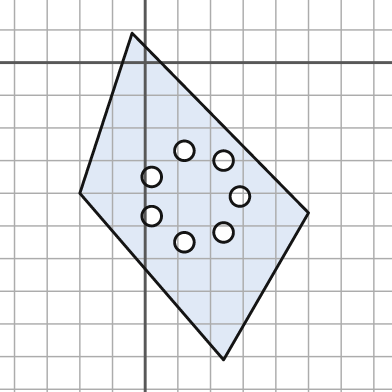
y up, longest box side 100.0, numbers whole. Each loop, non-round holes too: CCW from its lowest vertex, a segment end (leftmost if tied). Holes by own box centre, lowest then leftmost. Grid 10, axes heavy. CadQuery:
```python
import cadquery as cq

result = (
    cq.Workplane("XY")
    .moveTo(24.0, -91.0)
    .lineTo(50.0, -46.0)
    .lineTo(-4.0, 9.0)
    .lineTo(-20.0, -40.0)
    .close()
    .moveTo(12.0, -55.0)
    .circle(3.0)
    .moveTo(24.0, -52.0)
    .circle(3.0)
    .moveTo(2.0, -47.0)
    .circle(3.0)
    .moveTo(29.0, -41.0)
    .circle(3.0)
    .moveTo(2.0, -35.0)
    .circle(3.0)
    .moveTo(24.0, -30.0)
    .circle(3.0)
    .moveTo(12.0, -27.0)
    .circle(3.0)
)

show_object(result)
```